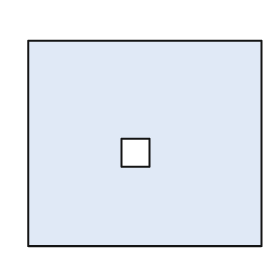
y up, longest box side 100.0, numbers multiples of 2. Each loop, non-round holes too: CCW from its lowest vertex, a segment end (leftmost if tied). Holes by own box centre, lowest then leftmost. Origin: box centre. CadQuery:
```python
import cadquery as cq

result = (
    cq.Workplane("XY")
    .moveTo(-50.0, -44.0)
    .lineTo(50.0, -44.0)
    .lineTo(50.0, 44.0)
    .lineTo(-50.0, 44.0)
    .close()
    .moveTo(-10.0, -10.0)
    .lineTo(2.0, -10.0)
    .lineTo(2.0, 2.0)
    .lineTo(-10.0, 2.0)
    .close()
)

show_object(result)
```